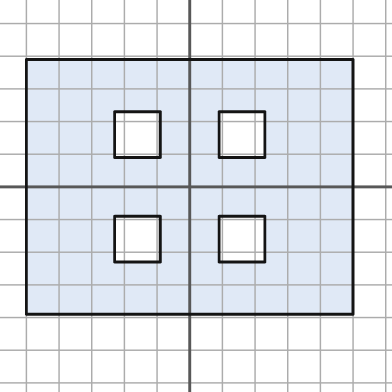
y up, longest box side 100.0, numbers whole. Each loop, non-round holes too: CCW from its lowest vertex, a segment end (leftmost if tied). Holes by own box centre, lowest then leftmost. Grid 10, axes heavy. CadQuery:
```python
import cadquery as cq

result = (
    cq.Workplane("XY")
    .moveTo(-50.0, -39.0)
    .lineTo(50.0, -39.0)
    .lineTo(50.0, 39.0)
    .lineTo(-50.0, 39.0)
    .close()
    .moveTo(-23.0, -23.0)
    .lineTo(-9.0, -23.0)
    .lineTo(-9.0, -9.0)
    .lineTo(-23.0, -9.0)
    .close()
    .moveTo(9.0, -23.0)
    .lineTo(23.0, -23.0)
    .lineTo(23.0, -9.0)
    .lineTo(9.0, -9.0)
    .close()
    .moveTo(-23.0, 9.0)
    .lineTo(-9.0, 9.0)
    .lineTo(-9.0, 23.0)
    .lineTo(-23.0, 23.0)
    .close()
    .moveTo(9.0, 9.0)
    .lineTo(23.0, 9.0)
    .lineTo(23.0, 23.0)
    .lineTo(9.0, 23.0)
    .close()
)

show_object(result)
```